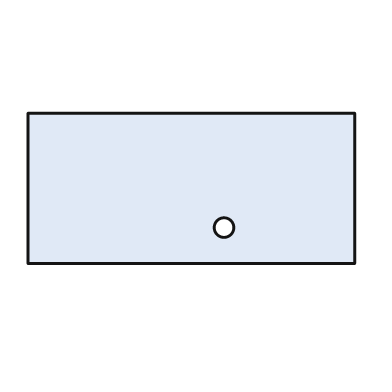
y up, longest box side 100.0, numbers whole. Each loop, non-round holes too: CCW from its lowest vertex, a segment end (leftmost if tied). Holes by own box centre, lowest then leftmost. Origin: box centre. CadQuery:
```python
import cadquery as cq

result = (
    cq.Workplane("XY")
    .moveTo(-50.0, -23.0)
    .lineTo(50.0, -23.0)
    .lineTo(50.0, 23.0)
    .lineTo(-50.0, 23.0)
    .close()
    .moveTo(10.0, -12.0)
    .circle(3.0)
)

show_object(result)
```